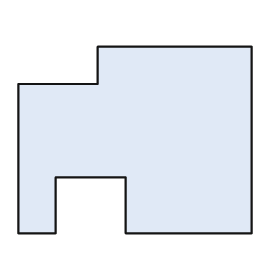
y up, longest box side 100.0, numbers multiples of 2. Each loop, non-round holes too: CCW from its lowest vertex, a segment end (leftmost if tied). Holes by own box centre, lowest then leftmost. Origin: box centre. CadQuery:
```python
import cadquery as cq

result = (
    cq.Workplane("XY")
    .moveTo(-50.0, -40.0)
    .lineTo(-34.0, -40.0)
    .lineTo(-34.0, -16.0)
    .lineTo(-4.0, -16.0)
    .lineTo(-4.0, -40.0)
    .lineTo(50.0, -40.0)
    .lineTo(50.0, 40.0)
    .lineTo(-16.0, 40.0)
    .lineTo(-16.0, 24.0)
    .lineTo(-50.0, 24.0)
    .close()
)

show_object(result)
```